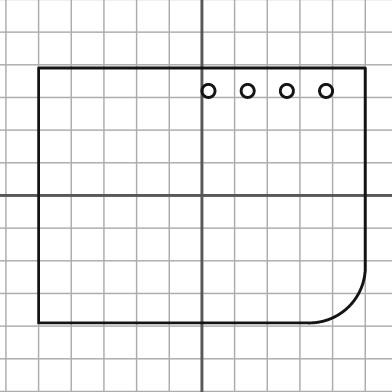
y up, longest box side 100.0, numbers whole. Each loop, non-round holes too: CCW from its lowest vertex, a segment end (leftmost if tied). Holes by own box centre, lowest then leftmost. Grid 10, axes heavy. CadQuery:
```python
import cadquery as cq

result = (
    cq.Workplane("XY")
    .moveTo(-50.0, -39.0)
    .lineTo(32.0, -39.0)
    .threePointArc((45.0, -34.0), (50.0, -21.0))
    .lineTo(50.0, 39.0)
    .lineTo(-50.0, 39.0)
    .close()
    .moveTo(2.0, 32.0)
    .circle(2.0)
    .moveTo(14.0, 32.0)
    .circle(2.0)
    .moveTo(26.0, 32.0)
    .circle(2.0)
    .moveTo(38.0, 32.0)
    .circle(2.0)
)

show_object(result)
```